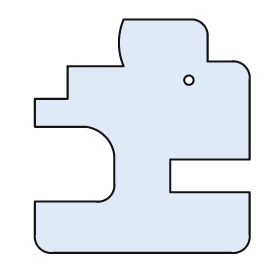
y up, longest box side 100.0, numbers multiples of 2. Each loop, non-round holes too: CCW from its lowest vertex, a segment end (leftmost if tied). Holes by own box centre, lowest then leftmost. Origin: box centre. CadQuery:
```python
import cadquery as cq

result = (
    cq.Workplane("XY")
    .moveTo(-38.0, -50.0)
    .lineTo(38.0, -50.0)
    .threePointArc((44.0, -48.0), (46.0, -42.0))
    .lineTo(46.0, -24.0)
    .lineTo(12.0, -24.0)
    .lineTo(12.0, -10.0)
    .lineTo(46.0, -10.0)
    .lineTo(46.0, 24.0)
    .threePointArc((44.0, 30.0), (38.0, 32.0))
    .lineTo(28.0, 32.0)
    .lineTo(28.0, 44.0)
    .threePointArc((26.0, 48.0), (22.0, 50.0))
    .lineTo(-8.0, 50.0)
    .threePointArc((-10.0, 40.0), (-8.0, 30.0))
    .lineTo(-32.0, 30.0)
    .lineTo(-32.0, 16.0)
    .lineTo(-46.0, 16.0)
    .lineTo(-46.0, 4.0)
    .lineTo(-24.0, 4.0)
    .threePointArc((-16.0, 0.0), (-12.0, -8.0))
    .lineTo(-12.0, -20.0)
    .threePointArc((-14.0, -26.0), (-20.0, -28.0))
    .lineTo(-46.0, -28.0)
    .lineTo(-46.0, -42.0)
    .threePointArc((-44.0, -48.0), (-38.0, -50.0))
    .close()
    .moveTo(20.0, 24.0)
    .circle(2.0)
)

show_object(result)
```